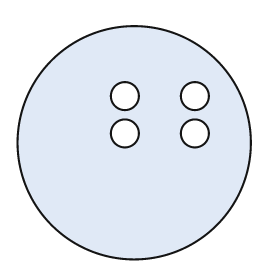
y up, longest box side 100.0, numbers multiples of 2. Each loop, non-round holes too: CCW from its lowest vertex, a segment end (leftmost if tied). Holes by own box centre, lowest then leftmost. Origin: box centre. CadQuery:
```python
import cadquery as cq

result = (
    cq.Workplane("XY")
    .moveTo(0.0, 0.0)
    .circle(50.0)
    .moveTo(-4.0, 4.0)
    .circle(6.0)
    .moveTo(26.0, 4.0)
    .circle(6.0)
    .moveTo(-4.0, 20.0)
    .circle(6.0)
    .moveTo(26.0, 20.0)
    .circle(6.0)
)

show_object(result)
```